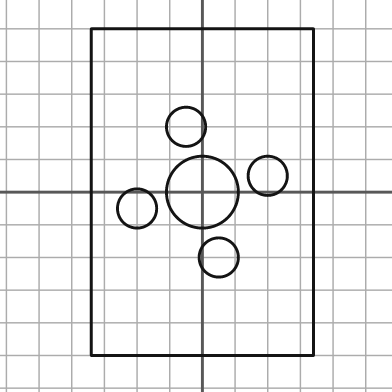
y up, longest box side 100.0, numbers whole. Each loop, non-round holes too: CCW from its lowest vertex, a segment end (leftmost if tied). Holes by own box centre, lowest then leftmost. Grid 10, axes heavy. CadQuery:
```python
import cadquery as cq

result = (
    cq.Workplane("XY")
    .moveTo(-34.0, -50.0)
    .lineTo(34.0, -50.0)
    .lineTo(34.0, 50.0)
    .lineTo(-34.0, 50.0)
    .close()
    .moveTo(5.0, -20.0)
    .circle(6.0)
    .moveTo(-20.0, -5.0)
    .circle(6.0)
    .moveTo(0.0, 0.0)
    .circle(11.0)
    .moveTo(20.0, 5.0)
    .circle(6.0)
    .moveTo(-5.0, 20.0)
    .circle(6.0)
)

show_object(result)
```